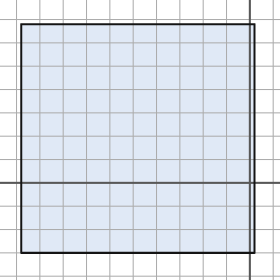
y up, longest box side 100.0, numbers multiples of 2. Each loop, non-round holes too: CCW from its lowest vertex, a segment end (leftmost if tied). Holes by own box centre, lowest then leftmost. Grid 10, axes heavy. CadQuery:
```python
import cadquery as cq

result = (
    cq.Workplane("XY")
    .moveTo(-98.0, -30.0)
    .lineTo(2.0, -30.0)
    .lineTo(2.0, 68.0)
    .lineTo(-98.0, 68.0)
    .close()
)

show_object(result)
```